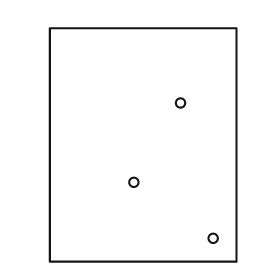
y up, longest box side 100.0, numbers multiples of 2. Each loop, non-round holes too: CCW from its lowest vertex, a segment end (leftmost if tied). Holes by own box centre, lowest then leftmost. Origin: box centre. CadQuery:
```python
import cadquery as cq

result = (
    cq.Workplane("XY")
    .moveTo(-40.0, -50.0)
    .lineTo(40.0, -50.0)
    .lineTo(40.0, 50.0)
    .lineTo(-40.0, 50.0)
    .close()
    .moveTo(30.0, -40.0)
    .circle(2.0)
    .moveTo(-4.0, -16.0)
    .circle(2.0)
    .moveTo(16.0, 18.0)
    .circle(2.0)
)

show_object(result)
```